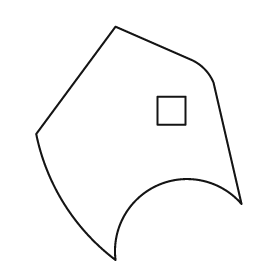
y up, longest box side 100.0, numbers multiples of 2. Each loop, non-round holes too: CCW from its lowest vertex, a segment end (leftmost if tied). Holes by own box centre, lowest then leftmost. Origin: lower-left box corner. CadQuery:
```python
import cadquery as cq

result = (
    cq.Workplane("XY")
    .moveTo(34.0, 0.0)
    .threePointArc((52.0, 32.0), (88.0, 24.0))
    .lineTo(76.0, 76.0)
    .threePointArc((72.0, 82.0), (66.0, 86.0))
    .lineTo(34.0, 100.0)
    .lineTo(0.0, 54.0)
    .threePointArc((12.0, 24.0), (34.0, 0.0))
    .close()
    .moveTo(52.0, 58.0)
    .lineTo(64.0, 58.0)
    .lineTo(64.0, 70.0)
    .lineTo(52.0, 70.0)
    .close()
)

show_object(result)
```